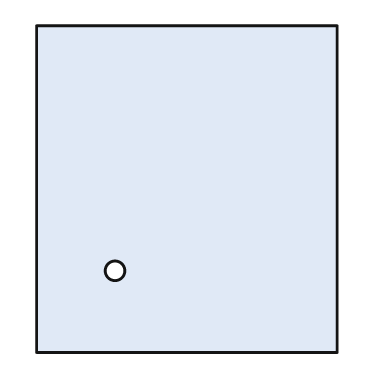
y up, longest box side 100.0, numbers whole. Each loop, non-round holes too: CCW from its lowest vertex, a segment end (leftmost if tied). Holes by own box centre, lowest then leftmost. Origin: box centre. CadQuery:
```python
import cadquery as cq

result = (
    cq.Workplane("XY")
    .moveTo(-46.0, -50.0)
    .lineTo(46.0, -50.0)
    .lineTo(46.0, 50.0)
    .lineTo(-46.0, 50.0)
    .close()
    .moveTo(-22.0, -25.0)
    .circle(3.0)
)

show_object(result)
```